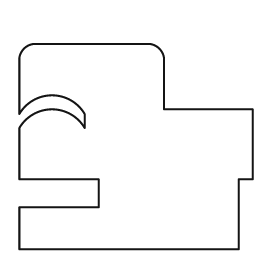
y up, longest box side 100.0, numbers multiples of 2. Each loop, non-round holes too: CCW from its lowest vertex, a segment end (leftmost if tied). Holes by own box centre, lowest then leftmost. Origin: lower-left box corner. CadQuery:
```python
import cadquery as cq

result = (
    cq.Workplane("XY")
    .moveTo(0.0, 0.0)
    .lineTo(94.0, 0.0)
    .lineTo(94.0, 30.0)
    .lineTo(100.0, 30.0)
    .lineTo(100.0, 60.0)
    .lineTo(62.0, 60.0)
    .lineTo(62.0, 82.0)
    .threePointArc((60.0, 86.0), (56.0, 88.0))
    .lineTo(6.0, 88.0)
    .threePointArc((2.0, 86.0), (0.0, 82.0))
    .lineTo(0.0, 58.0)
    .threePointArc((14.0, 66.0), (28.0, 58.0))
    .lineTo(28.0, 52.0)
    .threePointArc((14.0, 60.0), (0.0, 52.0))
    .lineTo(0.0, 30.0)
    .lineTo(34.0, 30.0)
    .lineTo(34.0, 18.0)
    .lineTo(0.0, 18.0)
    .close()
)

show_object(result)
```